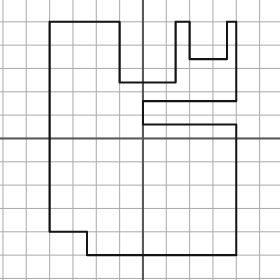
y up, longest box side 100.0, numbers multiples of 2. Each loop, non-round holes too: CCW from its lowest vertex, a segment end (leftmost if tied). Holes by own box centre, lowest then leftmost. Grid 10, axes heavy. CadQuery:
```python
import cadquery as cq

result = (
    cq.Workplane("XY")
    .moveTo(-24.0, -50.0)
    .lineTo(40.0, -50.0)
    .lineTo(40.0, 6.0)
    .lineTo(0.0, 6.0)
    .lineTo(0.0, 16.0)
    .lineTo(40.0, 16.0)
    .lineTo(40.0, 50.0)
    .lineTo(36.0, 50.0)
    .lineTo(36.0, 34.0)
    .lineTo(20.0, 34.0)
    .lineTo(20.0, 50.0)
    .lineTo(14.0, 50.0)
    .lineTo(14.0, 24.0)
    .lineTo(-10.0, 24.0)
    .lineTo(-10.0, 50.0)
    .lineTo(-40.0, 50.0)
    .lineTo(-40.0, -40.0)
    .lineTo(-24.0, -40.0)
    .close()
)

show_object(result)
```